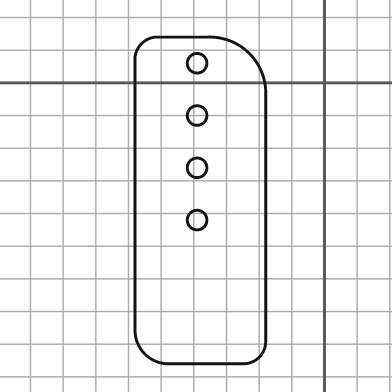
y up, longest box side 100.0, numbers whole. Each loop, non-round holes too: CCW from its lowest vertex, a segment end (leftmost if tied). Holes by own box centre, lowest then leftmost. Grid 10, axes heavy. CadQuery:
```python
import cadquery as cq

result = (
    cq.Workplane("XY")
    .moveTo(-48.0, -86.0)
    .lineTo(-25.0, -86.0)
    .threePointArc((-20.0, -84.0), (-18.0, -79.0))
    .lineTo(-18.0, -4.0)
    .threePointArc((-23.0, 9.0), (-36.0, 14.0))
    .lineTo(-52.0, 14.0)
    .threePointArc((-56.0, 12.0), (-58.0, 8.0))
    .lineTo(-58.0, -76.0)
    .threePointArc((-55.0, -83.0), (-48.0, -86.0))
    .close()
    .moveTo(-39.0, -42.0)
    .circle(3.0)
    .moveTo(-39.0, -26.0)
    .circle(3.0)
    .moveTo(-39.0, -10.0)
    .circle(3.0)
    .moveTo(-39.0, 6.0)
    .circle(3.0)
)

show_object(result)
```